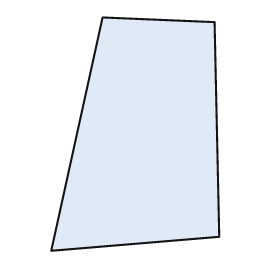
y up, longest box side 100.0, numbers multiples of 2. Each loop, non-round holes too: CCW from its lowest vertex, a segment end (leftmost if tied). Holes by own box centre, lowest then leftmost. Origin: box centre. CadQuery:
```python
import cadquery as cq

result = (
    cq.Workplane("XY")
    .moveTo(-36.0, -50.0)
    .lineTo(36.0, -44.0)
    .lineTo(34.0, 48.0)
    .lineTo(-14.0, 50.0)
    .close()
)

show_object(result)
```